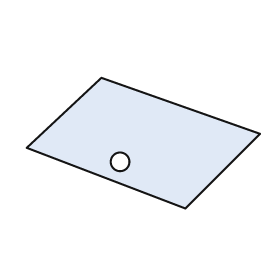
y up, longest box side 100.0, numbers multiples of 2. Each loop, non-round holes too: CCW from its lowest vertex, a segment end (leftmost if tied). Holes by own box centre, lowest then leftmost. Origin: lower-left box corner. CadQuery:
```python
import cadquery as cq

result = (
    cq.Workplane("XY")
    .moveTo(68.0, 0.0)
    .lineTo(100.0, 32.0)
    .lineTo(32.0, 56.0)
    .lineTo(0.0, 26.0)
    .close()
    .moveTo(40.0, 20.0)
    .circle(4.0)
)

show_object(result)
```